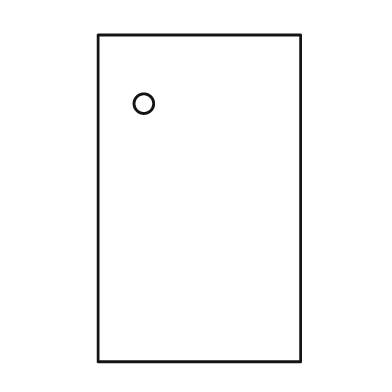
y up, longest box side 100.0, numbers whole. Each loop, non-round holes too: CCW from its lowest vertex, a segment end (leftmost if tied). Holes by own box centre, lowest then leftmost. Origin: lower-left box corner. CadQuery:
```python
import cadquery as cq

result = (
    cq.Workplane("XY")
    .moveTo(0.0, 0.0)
    .lineTo(62.0, 0.0)
    .lineTo(62.0, 100.0)
    .lineTo(0.0, 100.0)
    .close()
    .moveTo(14.0, 79.0)
    .circle(3.0)
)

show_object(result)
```